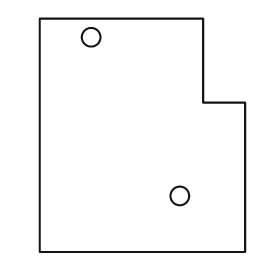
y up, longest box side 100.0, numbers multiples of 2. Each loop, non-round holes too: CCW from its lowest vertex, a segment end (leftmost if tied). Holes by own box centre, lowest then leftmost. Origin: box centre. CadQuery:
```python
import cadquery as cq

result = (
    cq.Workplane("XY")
    .moveTo(-44.0, -50.0)
    .lineTo(44.0, -50.0)
    .lineTo(44.0, 14.0)
    .lineTo(26.0, 14.0)
    .lineTo(26.0, 50.0)
    .lineTo(-44.0, 50.0)
    .close()
    .moveTo(16.0, -26.0)
    .circle(4.0)
    .moveTo(-22.0, 42.0)
    .circle(4.0)
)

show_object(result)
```